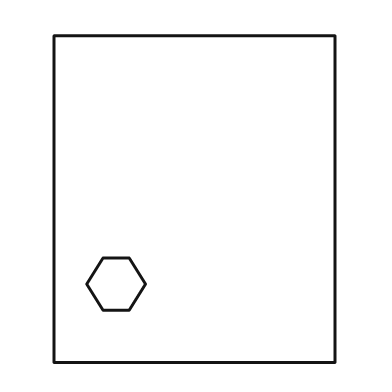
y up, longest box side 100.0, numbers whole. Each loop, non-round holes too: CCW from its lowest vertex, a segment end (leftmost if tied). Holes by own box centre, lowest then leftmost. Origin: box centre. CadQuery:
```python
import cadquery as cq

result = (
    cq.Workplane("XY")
    .moveTo(-43.0, -50.0)
    .lineTo(43.0, -50.0)
    .lineTo(43.0, 50.0)
    .lineTo(-43.0, 50.0)
    .close()
    .moveTo(-28.0, -34.0)
    .lineTo(-20.0, -34.0)
    .lineTo(-15.0, -26.0)
    .lineTo(-20.0, -18.0)
    .lineTo(-28.0, -18.0)
    .lineTo(-33.0, -26.0)
    .close()
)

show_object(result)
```